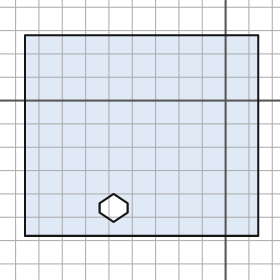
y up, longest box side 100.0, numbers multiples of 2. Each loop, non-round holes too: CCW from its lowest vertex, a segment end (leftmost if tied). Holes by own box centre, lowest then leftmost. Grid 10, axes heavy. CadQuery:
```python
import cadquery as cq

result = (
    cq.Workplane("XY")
    .moveTo(-86.0, -58.0)
    .lineTo(14.0, -58.0)
    .lineTo(14.0, 28.0)
    .lineTo(-86.0, 28.0)
    .close()
    .moveTo(-48.0, -52.0)
    .lineTo(-42.0, -48.0)
    .lineTo(-42.0, -44.0)
    .lineTo(-48.0, -40.0)
    .lineTo(-54.0, -44.0)
    .lineTo(-54.0, -48.0)
    .close()
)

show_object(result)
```